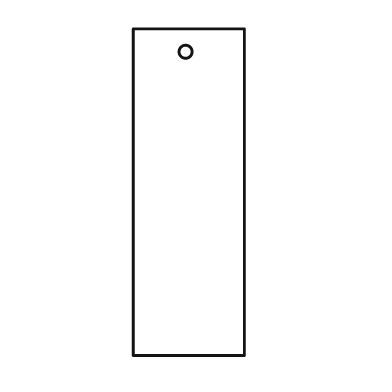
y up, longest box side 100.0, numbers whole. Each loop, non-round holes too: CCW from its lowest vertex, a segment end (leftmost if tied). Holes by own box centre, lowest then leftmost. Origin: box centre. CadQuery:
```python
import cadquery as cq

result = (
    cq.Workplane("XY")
    .moveTo(-17.0, -50.0)
    .lineTo(17.0, -50.0)
    .lineTo(17.0, 50.0)
    .lineTo(-17.0, 50.0)
    .close()
    .moveTo(-1.0, 43.0)
    .circle(2.0)
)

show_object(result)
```